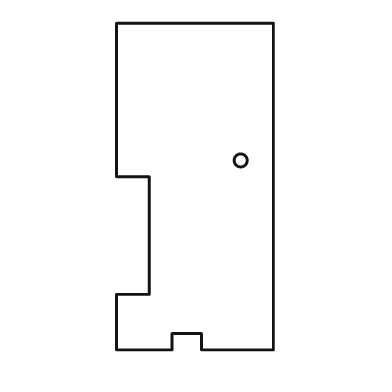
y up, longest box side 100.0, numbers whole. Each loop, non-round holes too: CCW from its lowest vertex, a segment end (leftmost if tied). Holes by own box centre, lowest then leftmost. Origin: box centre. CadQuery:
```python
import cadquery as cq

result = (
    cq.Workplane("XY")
    .moveTo(-24.0, -50.0)
    .lineTo(-7.0, -50.0)
    .lineTo(-7.0, -45.0)
    .lineTo(2.0, -45.0)
    .lineTo(2.0, -50.0)
    .lineTo(24.0, -50.0)
    .lineTo(24.0, 50.0)
    .lineTo(-24.0, 50.0)
    .lineTo(-24.0, 3.0)
    .lineTo(-14.0, 3.0)
    .lineTo(-14.0, -33.0)
    .lineTo(-24.0, -33.0)
    .close()
    .moveTo(14.0, 8.0)
    .circle(2.0)
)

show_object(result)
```